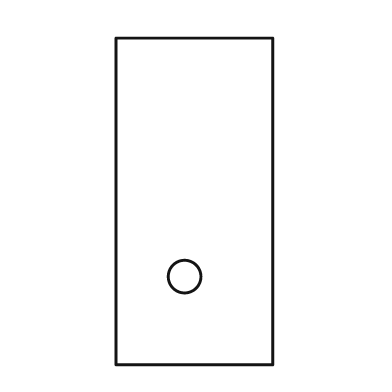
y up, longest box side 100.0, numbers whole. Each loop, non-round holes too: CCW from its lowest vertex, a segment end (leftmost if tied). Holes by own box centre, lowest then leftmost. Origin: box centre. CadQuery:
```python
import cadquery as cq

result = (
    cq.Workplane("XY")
    .moveTo(-24.0, -50.0)
    .lineTo(24.0, -50.0)
    .lineTo(24.0, 50.0)
    .lineTo(-24.0, 50.0)
    .close()
    .moveTo(-3.0, -23.0)
    .circle(5.0)
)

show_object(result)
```